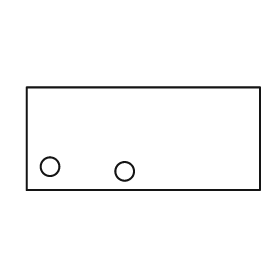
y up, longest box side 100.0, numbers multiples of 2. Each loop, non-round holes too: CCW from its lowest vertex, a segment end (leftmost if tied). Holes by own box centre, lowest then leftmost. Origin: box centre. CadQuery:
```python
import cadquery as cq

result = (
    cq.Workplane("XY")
    .moveTo(-50.0, -22.0)
    .lineTo(50.0, -22.0)
    .lineTo(50.0, 22.0)
    .lineTo(-50.0, 22.0)
    .close()
    .moveTo(-8.0, -14.0)
    .circle(4.0)
    .moveTo(-40.0, -12.0)
    .circle(4.0)
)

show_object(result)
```